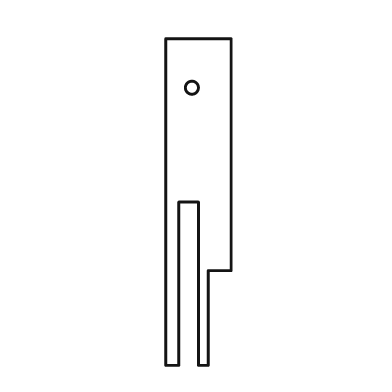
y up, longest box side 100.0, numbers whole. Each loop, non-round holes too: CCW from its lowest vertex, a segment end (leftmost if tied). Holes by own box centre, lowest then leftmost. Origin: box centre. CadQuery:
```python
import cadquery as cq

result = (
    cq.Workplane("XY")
    .moveTo(-10.0, -50.0)
    .lineTo(-6.0, -50.0)
    .lineTo(-6.0, 0.0)
    .lineTo(0.0, 0.0)
    .lineTo(0.0, -50.0)
    .lineTo(3.0, -50.0)
    .lineTo(3.0, -21.0)
    .lineTo(10.0, -21.0)
    .lineTo(10.0, 50.0)
    .lineTo(-10.0, 50.0)
    .close()
    .moveTo(-2.0, 35.0)
    .circle(2.0)
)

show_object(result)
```